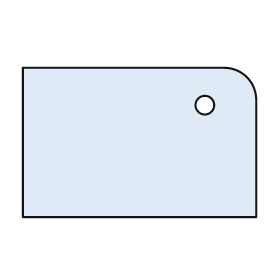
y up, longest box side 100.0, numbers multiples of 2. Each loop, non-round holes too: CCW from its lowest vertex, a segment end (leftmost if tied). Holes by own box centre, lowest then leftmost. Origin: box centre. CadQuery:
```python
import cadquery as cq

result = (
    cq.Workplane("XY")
    .moveTo(-50.0, -32.0)
    .lineTo(50.0, -32.0)
    .lineTo(50.0, 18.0)
    .threePointArc((46.0, 28.0), (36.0, 32.0))
    .lineTo(-50.0, 32.0)
    .close()
    .moveTo(28.0, 16.0)
    .circle(4.0)
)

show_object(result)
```